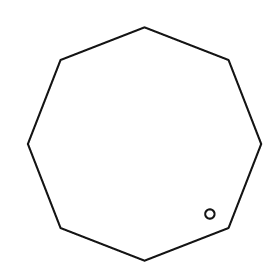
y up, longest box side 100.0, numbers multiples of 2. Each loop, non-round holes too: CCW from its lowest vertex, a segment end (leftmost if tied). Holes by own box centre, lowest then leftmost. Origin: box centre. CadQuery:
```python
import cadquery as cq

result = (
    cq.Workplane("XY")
    .moveTo(0.0, -50.0)
    .lineTo(36.0, -36.0)
    .lineTo(50.0, 0.0)
    .lineTo(36.0, 36.0)
    .lineTo(0.0, 50.0)
    .lineTo(-36.0, 36.0)
    .lineTo(-50.0, 0.0)
    .lineTo(-36.0, -36.0)
    .close()
    .moveTo(28.0, -30.0)
    .circle(2.0)
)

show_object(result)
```